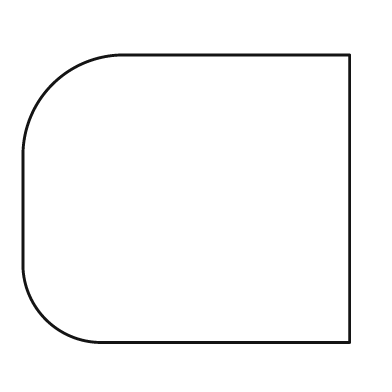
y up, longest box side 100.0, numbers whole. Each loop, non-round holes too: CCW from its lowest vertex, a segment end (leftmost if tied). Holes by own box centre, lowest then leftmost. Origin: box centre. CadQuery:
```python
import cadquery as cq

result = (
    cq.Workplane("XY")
    .moveTo(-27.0, -44.0)
    .lineTo(50.0, -44.0)
    .lineTo(50.0, 44.0)
    .lineTo(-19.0, 44.0)
    .threePointArc((-41.0, 35.0), (-50.0, 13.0))
    .lineTo(-50.0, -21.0)
    .threePointArc((-43.0, -37.0), (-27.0, -44.0))
    .close()
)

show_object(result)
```